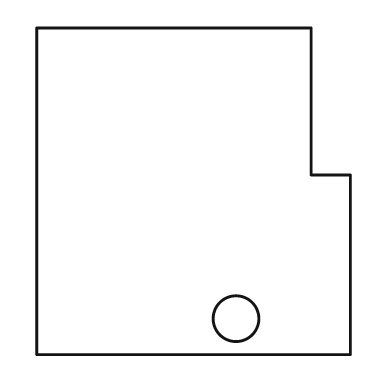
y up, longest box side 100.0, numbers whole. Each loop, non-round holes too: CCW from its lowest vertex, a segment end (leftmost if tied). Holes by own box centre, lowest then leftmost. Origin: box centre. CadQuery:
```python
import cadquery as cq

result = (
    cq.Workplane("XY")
    .moveTo(-48.0, -50.0)
    .lineTo(48.0, -50.0)
    .lineTo(48.0, 5.0)
    .lineTo(36.0, 5.0)
    .lineTo(36.0, 50.0)
    .lineTo(-48.0, 50.0)
    .close()
    .moveTo(13.0, -39.0)
    .circle(7.0)
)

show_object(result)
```